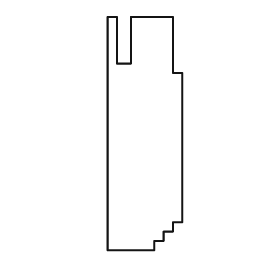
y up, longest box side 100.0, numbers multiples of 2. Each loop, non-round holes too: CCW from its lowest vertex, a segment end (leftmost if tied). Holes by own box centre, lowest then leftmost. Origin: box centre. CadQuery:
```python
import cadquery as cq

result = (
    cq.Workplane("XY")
    .moveTo(-16.0, -50.0)
    .lineTo(4.0, -50.0)
    .lineTo(4.0, -46.0)
    .lineTo(8.0, -46.0)
    .lineTo(8.0, -42.0)
    .lineTo(12.0, -42.0)
    .lineTo(12.0, -38.0)
    .lineTo(16.0, -38.0)
    .lineTo(16.0, 26.0)
    .lineTo(12.0, 26.0)
    .lineTo(12.0, 50.0)
    .lineTo(-6.0, 50.0)
    .lineTo(-6.0, 30.0)
    .lineTo(-12.0, 30.0)
    .lineTo(-12.0, 50.0)
    .lineTo(-16.0, 50.0)
    .close()
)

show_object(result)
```